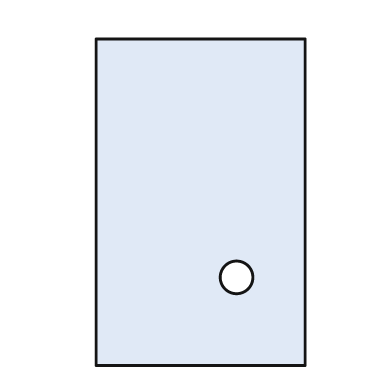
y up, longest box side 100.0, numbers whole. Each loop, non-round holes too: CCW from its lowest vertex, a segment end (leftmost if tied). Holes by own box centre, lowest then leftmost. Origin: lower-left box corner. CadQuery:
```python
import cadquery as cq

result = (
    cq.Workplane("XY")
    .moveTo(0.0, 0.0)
    .lineTo(64.0, 0.0)
    .lineTo(64.0, 100.0)
    .lineTo(0.0, 100.0)
    .close()
    .moveTo(43.0, 27.0)
    .circle(5.0)
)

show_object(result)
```